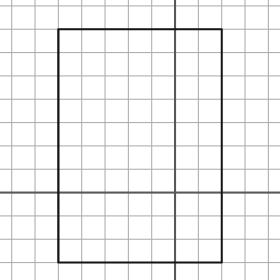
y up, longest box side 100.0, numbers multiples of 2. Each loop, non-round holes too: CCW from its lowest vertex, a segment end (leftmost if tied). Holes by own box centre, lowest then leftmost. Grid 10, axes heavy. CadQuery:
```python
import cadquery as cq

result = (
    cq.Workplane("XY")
    .moveTo(-50.0, -30.0)
    .lineTo(20.0, -30.0)
    .lineTo(20.0, 70.0)
    .lineTo(-50.0, 70.0)
    .close()
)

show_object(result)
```